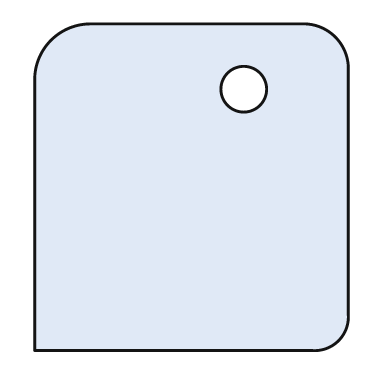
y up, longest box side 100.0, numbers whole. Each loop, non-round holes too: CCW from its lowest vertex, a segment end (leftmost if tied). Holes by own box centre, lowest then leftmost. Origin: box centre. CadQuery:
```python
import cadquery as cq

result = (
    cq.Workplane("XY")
    .moveTo(-48.0, -50.0)
    .lineTo(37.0, -50.0)
    .threePointArc((45.0, -47.0), (48.0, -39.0))
    .lineTo(48.0, 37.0)
    .threePointArc((44.0, 46.0), (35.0, 50.0))
    .lineTo(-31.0, 50.0)
    .threePointArc((-43.0, 45.0), (-48.0, 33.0))
    .close()
    .moveTo(16.0, 30.0)
    .circle(7.0)
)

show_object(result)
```